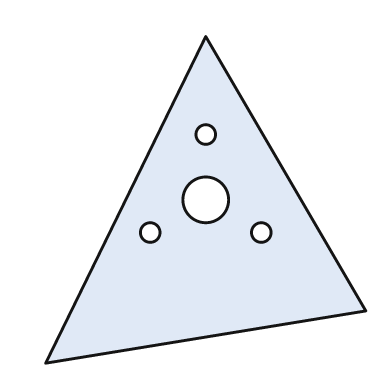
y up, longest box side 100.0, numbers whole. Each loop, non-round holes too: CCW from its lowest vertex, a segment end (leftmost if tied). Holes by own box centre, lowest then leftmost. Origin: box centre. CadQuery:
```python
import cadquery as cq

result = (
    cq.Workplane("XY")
    .moveTo(-49.0, -50.0)
    .lineTo(49.0, -34.0)
    .lineTo(0.0, 50.0)
    .close()
    .moveTo(-17.0, -10.0)
    .circle(3.0)
    .moveTo(17.0, -10.0)
    .circle(3.0)
    .moveTo(0.0, 0.0)
    .circle(7.0)
    .moveTo(0.0, 20.0)
    .circle(3.0)
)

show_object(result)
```